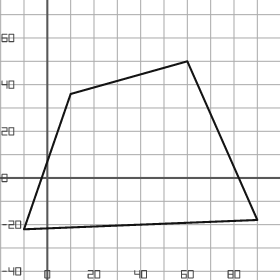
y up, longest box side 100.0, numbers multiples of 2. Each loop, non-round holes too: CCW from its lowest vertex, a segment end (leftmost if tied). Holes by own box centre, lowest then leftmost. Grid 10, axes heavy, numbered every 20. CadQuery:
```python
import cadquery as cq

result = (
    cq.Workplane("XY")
    .moveTo(-10.0, -22.0)
    .lineTo(90.0, -18.0)
    .lineTo(60.0, 50.0)
    .lineTo(10.0, 36.0)
    .close()
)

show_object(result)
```